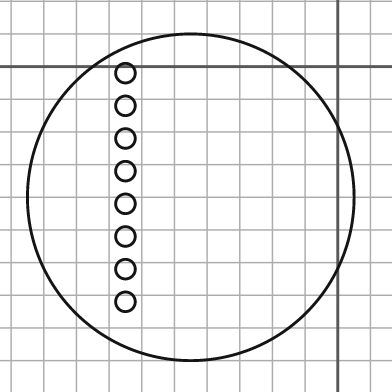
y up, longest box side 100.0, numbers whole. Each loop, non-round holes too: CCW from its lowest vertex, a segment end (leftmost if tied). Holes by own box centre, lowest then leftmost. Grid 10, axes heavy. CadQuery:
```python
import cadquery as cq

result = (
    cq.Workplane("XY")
    .moveTo(-45.0, -40.0)
    .circle(50.0)
    .moveTo(-65.0, -72.0)
    .circle(3.0)
    .moveTo(-65.0, -62.0)
    .circle(3.0)
    .moveTo(-65.0, -52.0)
    .circle(3.0)
    .moveTo(-65.0, -42.0)
    .circle(3.0)
    .moveTo(-65.0, -32.0)
    .circle(3.0)
    .moveTo(-65.0, -22.0)
    .circle(3.0)
    .moveTo(-65.0, -12.0)
    .circle(3.0)
    .moveTo(-65.0, -2.0)
    .circle(3.0)
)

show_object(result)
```